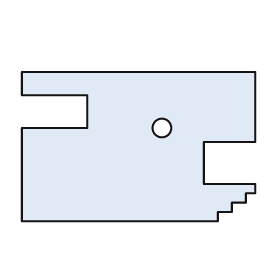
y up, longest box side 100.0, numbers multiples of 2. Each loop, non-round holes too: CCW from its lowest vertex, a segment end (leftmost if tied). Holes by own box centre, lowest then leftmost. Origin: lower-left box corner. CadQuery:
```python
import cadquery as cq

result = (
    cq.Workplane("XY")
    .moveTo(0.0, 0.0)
    .lineTo(84.0, 0.0)
    .lineTo(84.0, 4.0)
    .lineTo(90.0, 4.0)
    .lineTo(90.0, 8.0)
    .lineTo(96.0, 8.0)
    .lineTo(96.0, 12.0)
    .lineTo(100.0, 12.0)
    .lineTo(100.0, 16.0)
    .lineTo(78.0, 16.0)
    .lineTo(78.0, 34.0)
    .lineTo(100.0, 34.0)
    .lineTo(100.0, 64.0)
    .lineTo(0.0, 64.0)
    .lineTo(0.0, 54.0)
    .lineTo(28.0, 54.0)
    .lineTo(28.0, 40.0)
    .lineTo(0.0, 40.0)
    .close()
    .moveTo(60.0, 40.0)
    .circle(4.0)
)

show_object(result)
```